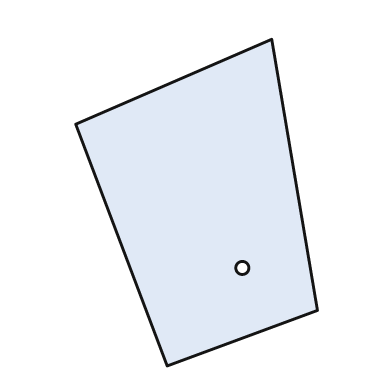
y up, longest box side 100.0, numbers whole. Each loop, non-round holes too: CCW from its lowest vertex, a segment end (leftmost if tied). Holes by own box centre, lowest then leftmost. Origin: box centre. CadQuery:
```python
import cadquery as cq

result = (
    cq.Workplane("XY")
    .moveTo(-9.0, -50.0)
    .lineTo(37.0, -33.0)
    .lineTo(23.0, 50.0)
    .lineTo(-37.0, 24.0)
    .close()
    .moveTo(14.0, -20.0)
    .circle(2.0)
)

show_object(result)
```